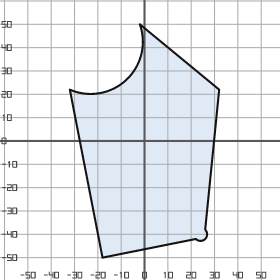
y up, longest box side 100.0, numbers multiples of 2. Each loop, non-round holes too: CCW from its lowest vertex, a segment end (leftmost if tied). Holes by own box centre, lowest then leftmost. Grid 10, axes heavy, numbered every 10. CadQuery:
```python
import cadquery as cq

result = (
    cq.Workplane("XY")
    .moveTo(-18.0, -50.0)
    .lineTo(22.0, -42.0)
    .threePointArc((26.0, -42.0), (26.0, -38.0))
    .lineTo(32.0, 22.0)
    .lineTo(-2.0, 50.0)
    .threePointArc((-8.0, 26.0), (-32.0, 22.0))
    .close()
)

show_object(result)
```